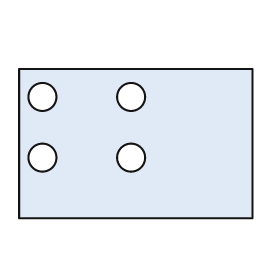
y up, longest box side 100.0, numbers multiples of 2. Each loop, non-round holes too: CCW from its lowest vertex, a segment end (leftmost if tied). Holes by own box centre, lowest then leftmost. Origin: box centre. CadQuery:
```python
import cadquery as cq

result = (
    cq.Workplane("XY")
    .moveTo(-50.0, -32.0)
    .lineTo(50.0, -32.0)
    .lineTo(50.0, 32.0)
    .lineTo(-50.0, 32.0)
    .close()
    .moveTo(-40.0, -6.0)
    .circle(6.0)
    .moveTo(-2.0, -6.0)
    .circle(6.0)
    .moveTo(-40.0, 20.0)
    .circle(6.0)
    .moveTo(-2.0, 20.0)
    .circle(6.0)
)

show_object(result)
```